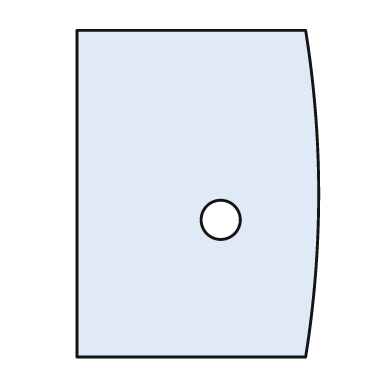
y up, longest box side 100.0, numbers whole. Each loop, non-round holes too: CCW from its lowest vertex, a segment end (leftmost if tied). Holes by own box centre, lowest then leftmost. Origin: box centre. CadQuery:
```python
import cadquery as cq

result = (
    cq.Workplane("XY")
    .moveTo(-37.0, -50.0)
    .lineTo(33.0, -50.0)
    .threePointArc((37.0, 0.0), (33.0, 50.0))
    .lineTo(-37.0, 50.0)
    .close()
    .moveTo(7.0, -8.0)
    .circle(6.0)
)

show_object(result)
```